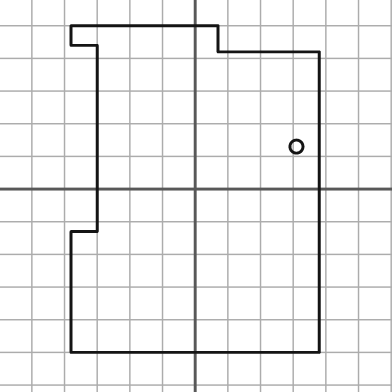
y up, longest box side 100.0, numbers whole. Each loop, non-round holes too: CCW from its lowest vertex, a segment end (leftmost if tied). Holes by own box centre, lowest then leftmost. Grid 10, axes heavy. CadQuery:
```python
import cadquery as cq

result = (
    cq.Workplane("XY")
    .moveTo(-38.0, -50.0)
    .lineTo(38.0, -50.0)
    .lineTo(38.0, 42.0)
    .lineTo(7.0, 42.0)
    .lineTo(7.0, 50.0)
    .lineTo(-38.0, 50.0)
    .lineTo(-38.0, 44.0)
    .lineTo(-30.0, 44.0)
    .lineTo(-30.0, -13.0)
    .lineTo(-38.0, -13.0)
    .close()
    .moveTo(31.0, 13.0)
    .circle(2.0)
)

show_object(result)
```